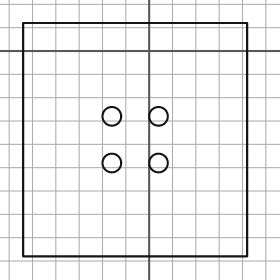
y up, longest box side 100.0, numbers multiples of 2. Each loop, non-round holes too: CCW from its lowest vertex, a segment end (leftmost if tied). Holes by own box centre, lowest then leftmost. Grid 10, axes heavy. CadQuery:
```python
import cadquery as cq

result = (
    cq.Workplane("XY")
    .moveTo(-54.0, -88.0)
    .lineTo(42.0, -88.0)
    .lineTo(42.0, 12.0)
    .lineTo(-54.0, 12.0)
    .close()
    .moveTo(-16.0, -48.0)
    .circle(4.0)
    .moveTo(4.0, -48.0)
    .circle(4.0)
    .moveTo(-16.0, -28.0)
    .circle(4.0)
    .moveTo(4.0, -28.0)
    .circle(4.0)
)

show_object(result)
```